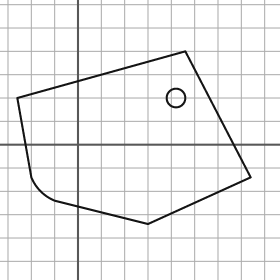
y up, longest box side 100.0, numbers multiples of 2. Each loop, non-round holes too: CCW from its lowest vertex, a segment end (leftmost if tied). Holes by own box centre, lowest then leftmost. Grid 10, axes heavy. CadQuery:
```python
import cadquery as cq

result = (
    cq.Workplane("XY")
    .moveTo(30.0, -34.0)
    .lineTo(74.0, -14.0)
    .lineTo(46.0, 40.0)
    .lineTo(-26.0, 20.0)
    .lineTo(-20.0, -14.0)
    .threePointArc((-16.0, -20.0), (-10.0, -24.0))
    .close()
    .moveTo(42.0, 20.0)
    .circle(4.0)
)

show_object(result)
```